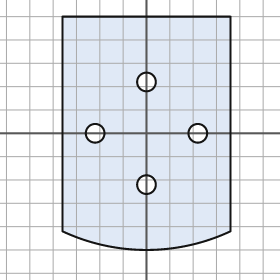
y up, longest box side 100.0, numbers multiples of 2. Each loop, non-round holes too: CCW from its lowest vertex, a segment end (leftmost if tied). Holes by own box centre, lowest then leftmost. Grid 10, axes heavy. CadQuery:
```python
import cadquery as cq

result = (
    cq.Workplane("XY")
    .moveTo(-36.0, -42.0)
    .threePointArc((0.0, -50.0), (36.0, -42.0))
    .lineTo(36.0, 50.0)
    .lineTo(-36.0, 50.0)
    .close()
    .moveTo(0.0, -22.0)
    .circle(4.0)
    .moveTo(-22.0, 0.0)
    .circle(4.0)
    .moveTo(22.0, 0.0)
    .circle(4.0)
    .moveTo(0.0, 22.0)
    .circle(4.0)
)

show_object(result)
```